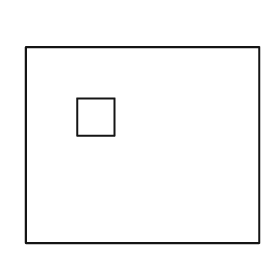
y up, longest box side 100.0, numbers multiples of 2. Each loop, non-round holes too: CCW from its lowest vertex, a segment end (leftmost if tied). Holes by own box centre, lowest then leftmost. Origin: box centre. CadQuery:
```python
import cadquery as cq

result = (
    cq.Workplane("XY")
    .moveTo(-50.0, -42.0)
    .lineTo(50.0, -42.0)
    .lineTo(50.0, 42.0)
    .lineTo(-50.0, 42.0)
    .close()
    .moveTo(-28.0, 4.0)
    .lineTo(-12.0, 4.0)
    .lineTo(-12.0, 20.0)
    .lineTo(-28.0, 20.0)
    .close()
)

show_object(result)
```